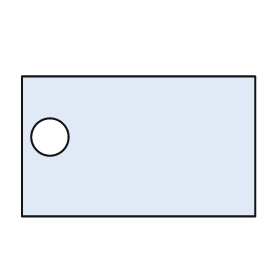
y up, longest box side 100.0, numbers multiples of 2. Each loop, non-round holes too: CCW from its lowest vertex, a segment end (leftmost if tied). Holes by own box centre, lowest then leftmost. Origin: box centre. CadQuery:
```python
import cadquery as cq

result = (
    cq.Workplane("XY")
    .moveTo(-50.0, -30.0)
    .lineTo(50.0, -30.0)
    .lineTo(50.0, 30.0)
    .lineTo(-50.0, 30.0)
    .close()
    .moveTo(-38.0, 4.0)
    .circle(8.0)
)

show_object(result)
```